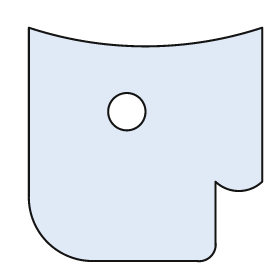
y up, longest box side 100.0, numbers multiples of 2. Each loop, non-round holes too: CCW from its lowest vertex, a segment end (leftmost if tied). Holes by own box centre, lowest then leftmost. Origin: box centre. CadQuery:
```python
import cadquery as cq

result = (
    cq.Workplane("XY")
    .moveTo(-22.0, -50.0)
    .lineTo(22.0, -50.0)
    .threePointArc((28.0, -48.0), (30.0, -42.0))
    .lineTo(30.0, -16.0)
    .threePointArc((40.0, -20.0), (50.0, -16.0))
    .lineTo(50.0, 50.0)
    .threePointArc((0.0, 42.0), (-50.0, 50.0))
    .lineTo(-50.0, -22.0)
    .threePointArc((-42.0, -42.0), (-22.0, -50.0))
    .close()
    .moveTo(-8.0, 14.0)
    .circle(8.0)
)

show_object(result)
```